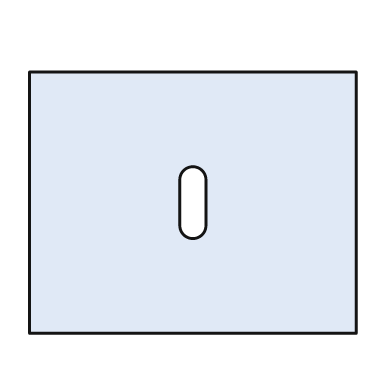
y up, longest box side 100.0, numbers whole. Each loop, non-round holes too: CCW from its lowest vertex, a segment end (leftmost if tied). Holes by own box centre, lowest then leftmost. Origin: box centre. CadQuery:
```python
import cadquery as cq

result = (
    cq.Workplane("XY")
    .moveTo(-50.0, -40.0)
    .lineTo(50.0, -40.0)
    .lineTo(50.0, 40.0)
    .lineTo(-50.0, 40.0)
    .close()
    .moveTo(-4.0, -7.0)
    .threePointArc((0.0, -11.0), (4.0, -7.0))
    .lineTo(4.0, 7.0)
    .threePointArc((0.0, 11.0), (-4.0, 7.0))
    .close()
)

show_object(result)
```